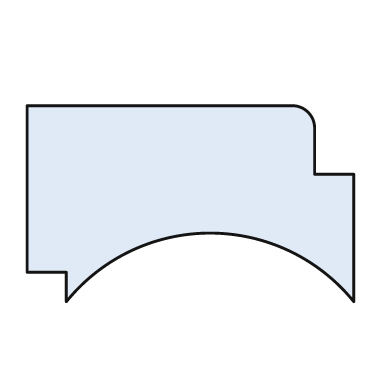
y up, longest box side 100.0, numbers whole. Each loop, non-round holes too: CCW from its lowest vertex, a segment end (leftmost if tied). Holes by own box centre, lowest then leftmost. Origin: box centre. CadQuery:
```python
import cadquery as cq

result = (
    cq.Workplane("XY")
    .moveTo(-38.0, -30.0)
    .threePointArc((6.0, -9.0), (50.0, -30.0))
    .lineTo(50.0, 9.0)
    .lineTo(38.0, 9.0)
    .lineTo(38.0, 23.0)
    .threePointArc((36.0, 28.0), (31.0, 30.0))
    .lineTo(-50.0, 30.0)
    .lineTo(-50.0, -21.0)
    .lineTo(-38.0, -21.0)
    .close()
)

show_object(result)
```